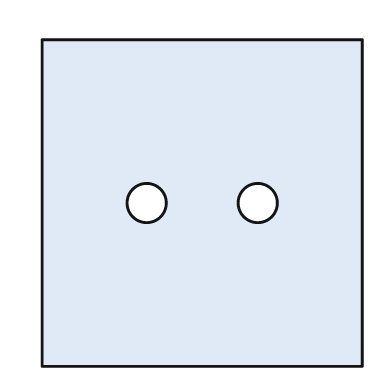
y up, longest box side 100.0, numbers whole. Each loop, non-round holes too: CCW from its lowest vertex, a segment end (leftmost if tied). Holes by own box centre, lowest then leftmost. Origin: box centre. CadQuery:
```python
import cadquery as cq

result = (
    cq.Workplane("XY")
    .moveTo(-49.0, -50.0)
    .lineTo(49.0, -50.0)
    .lineTo(49.0, 50.0)
    .lineTo(-49.0, 50.0)
    .close()
    .moveTo(-17.0, 0.0)
    .circle(6.0)
    .moveTo(17.0, 0.0)
    .circle(6.0)
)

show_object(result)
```